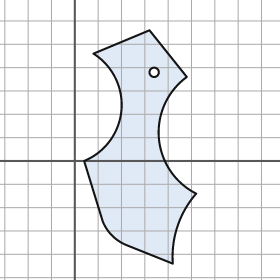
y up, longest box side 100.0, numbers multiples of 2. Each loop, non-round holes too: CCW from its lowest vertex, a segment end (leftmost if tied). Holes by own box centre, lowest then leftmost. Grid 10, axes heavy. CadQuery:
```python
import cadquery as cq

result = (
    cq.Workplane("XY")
    .moveTo(42.0, -44.0)
    .threePointArc((44.0, -28.0), (52.0, -14.0))
    .threePointArc((36.0, 10.0), (48.0, 36.0))
    .lineTo(32.0, 56.0)
    .lineTo(8.0, 46.0)
    .threePointArc((20.0, 22.0), (4.0, 0.0))
    .lineTo(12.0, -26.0)
    .threePointArc((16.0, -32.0), (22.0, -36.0))
    .close()
    .moveTo(34.0, 38.0)
    .circle(2.0)
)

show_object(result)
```